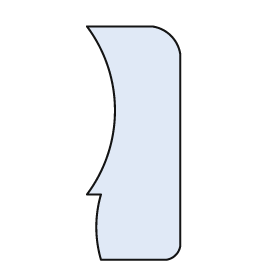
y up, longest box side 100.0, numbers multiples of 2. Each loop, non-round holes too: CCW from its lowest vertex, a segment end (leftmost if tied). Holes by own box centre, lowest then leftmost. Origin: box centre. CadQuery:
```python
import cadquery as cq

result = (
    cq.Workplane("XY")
    .moveTo(-14.0, -50.0)
    .lineTo(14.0, -50.0)
    .threePointArc((18.0, -48.0), (20.0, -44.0))
    .lineTo(20.0, 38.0)
    .threePointArc((16.0, 46.0), (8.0, 50.0))
    .lineTo(-20.0, 50.0)
    .threePointArc((-8.0, 14.0), (-20.0, -22.0))
    .lineTo(-14.0, -22.0)
    .threePointArc((-16.0, -36.0), (-14.0, -50.0))
    .close()
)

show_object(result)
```